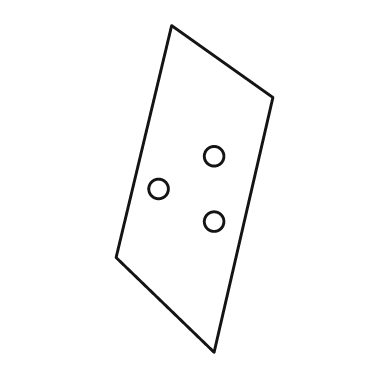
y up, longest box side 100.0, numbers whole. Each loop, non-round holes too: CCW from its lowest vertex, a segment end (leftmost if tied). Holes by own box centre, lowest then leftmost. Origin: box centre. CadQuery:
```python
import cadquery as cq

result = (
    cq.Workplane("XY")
    .moveTo(6.0, -50.0)
    .lineTo(24.0, 28.0)
    .lineTo(-7.0, 50.0)
    .lineTo(-24.0, -21.0)
    .close()
    .moveTo(6.0, -10.0)
    .circle(3.0)
    .moveTo(-11.0, 0.0)
    .circle(3.0)
    .moveTo(6.0, 10.0)
    .circle(3.0)
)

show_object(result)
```